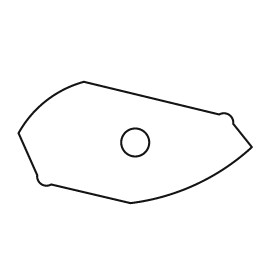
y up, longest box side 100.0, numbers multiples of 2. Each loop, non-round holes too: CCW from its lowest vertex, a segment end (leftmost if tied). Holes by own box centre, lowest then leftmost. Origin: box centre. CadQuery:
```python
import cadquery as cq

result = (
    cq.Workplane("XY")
    .moveTo(-2.0, -26.0)
    .threePointArc((26.0, -18.0), (50.0, -2.0))
    .lineTo(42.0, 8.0)
    .threePointArc((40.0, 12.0), (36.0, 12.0))
    .lineTo(-22.0, 26.0)
    .threePointArc((-38.0, 18.0), (-50.0, 4.0))
    .lineTo(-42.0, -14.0)
    .threePointArc((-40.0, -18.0), (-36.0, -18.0))
    .close()
    .moveTo(0.0, 0.0)
    .circle(6.0)
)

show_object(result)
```